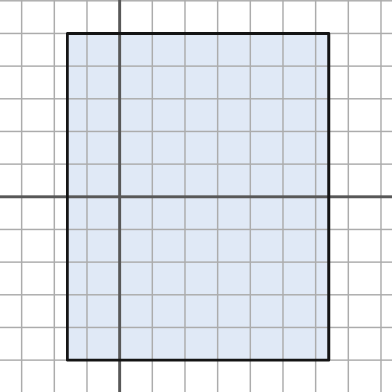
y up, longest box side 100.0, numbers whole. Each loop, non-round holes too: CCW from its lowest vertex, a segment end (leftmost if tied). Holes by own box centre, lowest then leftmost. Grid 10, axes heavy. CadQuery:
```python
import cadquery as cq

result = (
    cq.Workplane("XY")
    .moveTo(-16.0, -50.0)
    .lineTo(64.0, -50.0)
    .lineTo(64.0, 50.0)
    .lineTo(-16.0, 50.0)
    .close()
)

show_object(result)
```